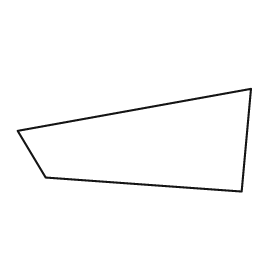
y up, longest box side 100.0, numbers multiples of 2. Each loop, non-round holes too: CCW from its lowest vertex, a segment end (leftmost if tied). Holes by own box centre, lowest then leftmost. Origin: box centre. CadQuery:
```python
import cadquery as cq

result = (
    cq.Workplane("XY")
    .moveTo(46.0, -22.0)
    .lineTo(50.0, 22.0)
    .lineTo(-50.0, 4.0)
    .lineTo(-38.0, -16.0)
    .close()
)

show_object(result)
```